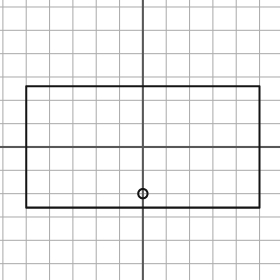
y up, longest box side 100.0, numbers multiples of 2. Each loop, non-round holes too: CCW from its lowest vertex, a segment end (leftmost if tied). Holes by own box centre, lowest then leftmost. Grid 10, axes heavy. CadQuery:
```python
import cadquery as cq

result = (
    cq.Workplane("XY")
    .moveTo(-50.0, -26.0)
    .lineTo(50.0, -26.0)
    .lineTo(50.0, 26.0)
    .lineTo(-50.0, 26.0)
    .close()
    .moveTo(0.0, -20.0)
    .circle(2.0)
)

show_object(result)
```